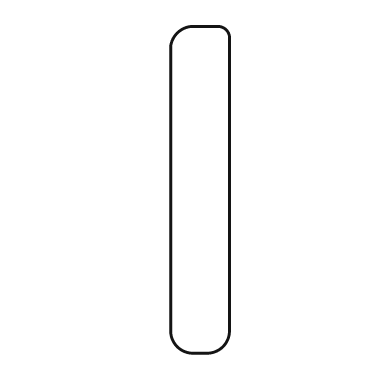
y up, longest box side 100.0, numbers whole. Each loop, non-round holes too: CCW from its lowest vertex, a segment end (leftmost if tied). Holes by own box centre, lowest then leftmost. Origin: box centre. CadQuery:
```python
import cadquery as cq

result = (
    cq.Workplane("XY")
    .moveTo(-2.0, -50.0)
    .lineTo(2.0, -50.0)
    .threePointArc((7.0, -48.0), (9.0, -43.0))
    .lineTo(9.0, 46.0)
    .threePointArc((8.0, 49.0), (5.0, 50.0))
    .lineTo(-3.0, 50.0)
    .threePointArc((-7.0, 48.0), (-9.0, 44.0))
    .lineTo(-9.0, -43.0)
    .threePointArc((-7.0, -48.0), (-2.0, -50.0))
    .close()
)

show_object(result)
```